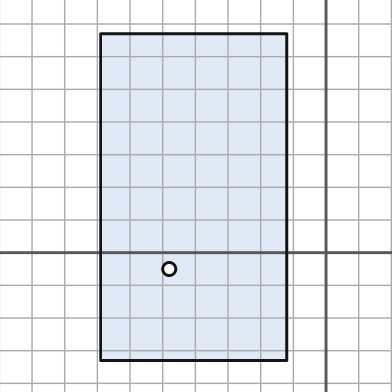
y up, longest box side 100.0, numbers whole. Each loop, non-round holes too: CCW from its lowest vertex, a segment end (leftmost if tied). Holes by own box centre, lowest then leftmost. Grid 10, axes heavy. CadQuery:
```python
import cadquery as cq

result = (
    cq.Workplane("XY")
    .moveTo(-69.0, -33.0)
    .lineTo(-12.0, -33.0)
    .lineTo(-12.0, 67.0)
    .lineTo(-69.0, 67.0)
    .close()
    .moveTo(-48.0, -5.0)
    .circle(2.0)
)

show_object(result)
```